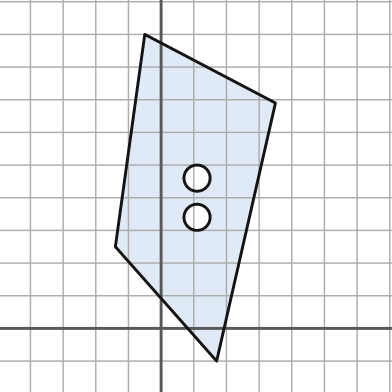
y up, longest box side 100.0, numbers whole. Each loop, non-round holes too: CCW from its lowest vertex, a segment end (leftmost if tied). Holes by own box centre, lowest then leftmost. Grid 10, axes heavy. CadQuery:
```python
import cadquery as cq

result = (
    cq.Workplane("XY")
    .moveTo(17.0, -10.0)
    .lineTo(35.0, 69.0)
    .lineTo(-5.0, 90.0)
    .lineTo(-14.0, 25.0)
    .close()
    .moveTo(11.0, 34.0)
    .circle(4.0)
    .moveTo(11.0, 46.0)
    .circle(4.0)
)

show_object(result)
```